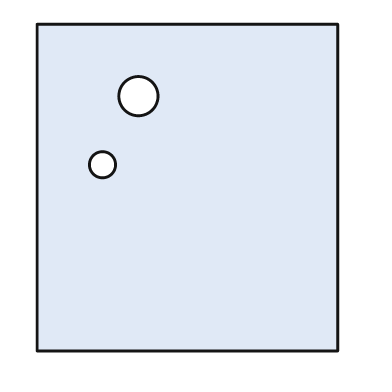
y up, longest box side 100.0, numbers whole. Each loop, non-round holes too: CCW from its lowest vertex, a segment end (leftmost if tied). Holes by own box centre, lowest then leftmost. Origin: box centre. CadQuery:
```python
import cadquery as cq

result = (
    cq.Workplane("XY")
    .moveTo(-46.0, -50.0)
    .lineTo(46.0, -50.0)
    .lineTo(46.0, 50.0)
    .lineTo(-46.0, 50.0)
    .close()
    .moveTo(-26.0, 7.0)
    .circle(4.0)
    .moveTo(-15.0, 28.0)
    .circle(6.0)
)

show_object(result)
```